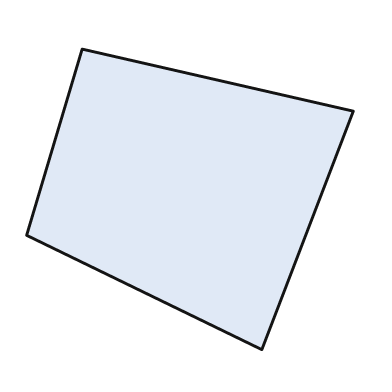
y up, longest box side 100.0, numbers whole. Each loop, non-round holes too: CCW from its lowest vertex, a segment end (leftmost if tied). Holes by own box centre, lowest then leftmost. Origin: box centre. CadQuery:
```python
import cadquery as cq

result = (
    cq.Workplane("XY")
    .moveTo(22.0, -46.0)
    .lineTo(50.0, 27.0)
    .lineTo(-33.0, 46.0)
    .lineTo(-50.0, -11.0)
    .close()
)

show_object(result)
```